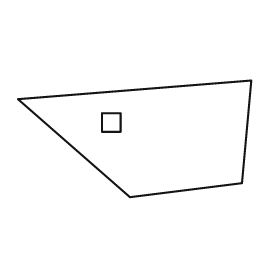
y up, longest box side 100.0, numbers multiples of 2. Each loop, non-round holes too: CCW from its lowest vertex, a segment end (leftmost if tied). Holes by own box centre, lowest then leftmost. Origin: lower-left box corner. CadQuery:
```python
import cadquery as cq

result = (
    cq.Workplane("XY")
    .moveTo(48.0, 0.0)
    .lineTo(96.0, 6.0)
    .lineTo(100.0, 50.0)
    .lineTo(0.0, 42.0)
    .close()
    .moveTo(36.0, 28.0)
    .lineTo(44.0, 28.0)
    .lineTo(44.0, 36.0)
    .lineTo(36.0, 36.0)
    .close()
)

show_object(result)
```